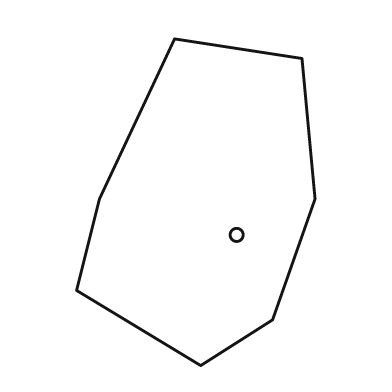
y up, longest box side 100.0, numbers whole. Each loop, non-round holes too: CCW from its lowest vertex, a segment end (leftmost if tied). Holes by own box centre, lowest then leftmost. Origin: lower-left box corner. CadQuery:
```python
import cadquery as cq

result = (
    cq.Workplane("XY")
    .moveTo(38.0, 0.0)
    .lineTo(60.0, 14.0)
    .lineTo(73.0, 51.0)
    .lineTo(69.0, 94.0)
    .lineTo(30.0, 100.0)
    .lineTo(7.0, 51.0)
    .lineTo(0.0, 23.0)
    .close()
    .moveTo(49.0, 40.0)
    .circle(2.0)
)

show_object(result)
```